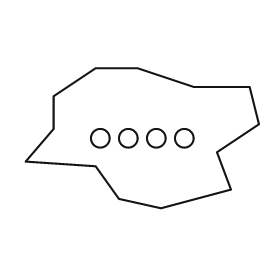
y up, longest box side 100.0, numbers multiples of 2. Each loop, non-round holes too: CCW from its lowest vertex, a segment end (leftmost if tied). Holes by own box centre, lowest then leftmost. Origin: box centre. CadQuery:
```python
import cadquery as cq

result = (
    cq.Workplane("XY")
    .moveTo(8.0, -30.0)
    .lineTo(38.0, -22.0)
    .lineTo(32.0, -6.0)
    .lineTo(50.0, 6.0)
    .lineTo(46.0, 22.0)
    .lineTo(22.0, 22.0)
    .lineTo(-2.0, 30.0)
    .lineTo(-20.0, 30.0)
    .lineTo(-38.0, 18.0)
    .lineTo(-38.0, 4.0)
    .lineTo(-50.0, -10.0)
    .lineTo(-20.0, -12.0)
    .lineTo(-10.0, -26.0)
    .close()
    .moveTo(-18.0, 0.0)
    .circle(4.0)
    .moveTo(-6.0, 0.0)
    .circle(4.0)
    .moveTo(6.0, 0.0)
    .circle(4.0)
    .moveTo(18.0, 0.0)
    .circle(4.0)
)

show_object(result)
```